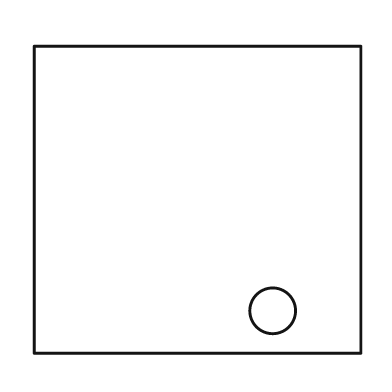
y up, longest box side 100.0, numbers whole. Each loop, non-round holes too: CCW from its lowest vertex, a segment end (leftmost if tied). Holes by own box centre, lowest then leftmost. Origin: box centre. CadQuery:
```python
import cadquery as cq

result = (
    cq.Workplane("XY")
    .moveTo(-50.0, -47.0)
    .lineTo(50.0, -47.0)
    .lineTo(50.0, 47.0)
    .lineTo(-50.0, 47.0)
    .close()
    .moveTo(23.0, -34.0)
    .circle(7.0)
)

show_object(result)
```